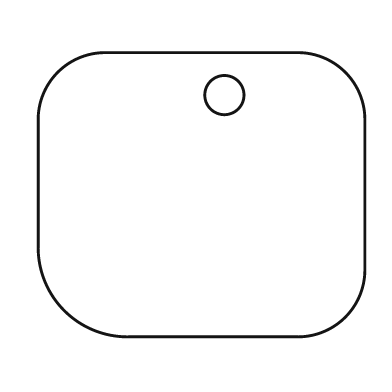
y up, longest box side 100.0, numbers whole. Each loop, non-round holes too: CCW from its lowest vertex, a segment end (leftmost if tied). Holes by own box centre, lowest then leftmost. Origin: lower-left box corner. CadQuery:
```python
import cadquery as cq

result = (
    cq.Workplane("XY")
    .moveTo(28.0, 0.0)
    .lineTo(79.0, 0.0)
    .threePointArc((94.0, 6.0), (100.0, 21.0))
    .lineTo(100.0, 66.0)
    .threePointArc((94.0, 81.0), (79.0, 87.0))
    .lineTo(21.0, 87.0)
    .threePointArc((6.0, 81.0), (0.0, 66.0))
    .lineTo(0.0, 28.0)
    .threePointArc((8.0, 8.0), (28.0, 0.0))
    .close()
    .moveTo(57.0, 74.0)
    .circle(6.0)
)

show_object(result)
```